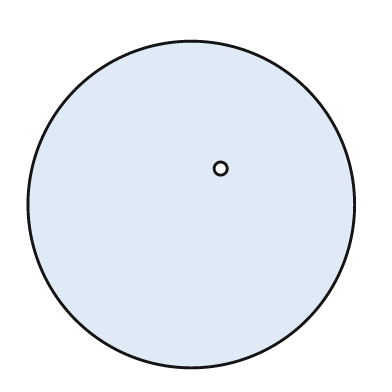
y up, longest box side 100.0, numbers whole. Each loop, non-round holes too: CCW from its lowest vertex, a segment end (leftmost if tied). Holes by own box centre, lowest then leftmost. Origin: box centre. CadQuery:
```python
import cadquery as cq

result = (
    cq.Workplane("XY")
    .moveTo(0.0, 0.0)
    .circle(50.0)
    .moveTo(9.0, 11.0)
    .circle(2.0)
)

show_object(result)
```